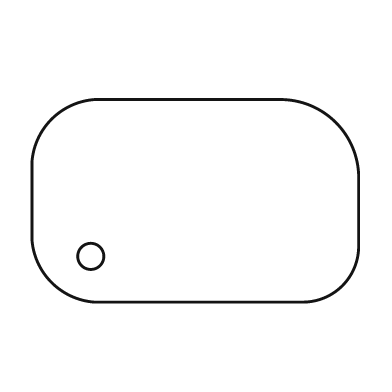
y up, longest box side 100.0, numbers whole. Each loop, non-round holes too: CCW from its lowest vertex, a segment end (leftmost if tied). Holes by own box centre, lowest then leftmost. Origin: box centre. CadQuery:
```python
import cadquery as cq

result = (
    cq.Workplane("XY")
    .moveTo(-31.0, -31.0)
    .lineTo(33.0, -31.0)
    .threePointArc((45.0, -26.0), (50.0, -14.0))
    .lineTo(50.0, 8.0)
    .threePointArc((43.0, 24.0), (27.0, 31.0))
    .lineTo(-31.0, 31.0)
    .threePointArc((-44.0, 25.0), (-50.0, 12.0))
    .lineTo(-50.0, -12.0)
    .threePointArc((-44.0, -25.0), (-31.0, -31.0))
    .close()
    .moveTo(-32.0, -17.0)
    .circle(4.0)
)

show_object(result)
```